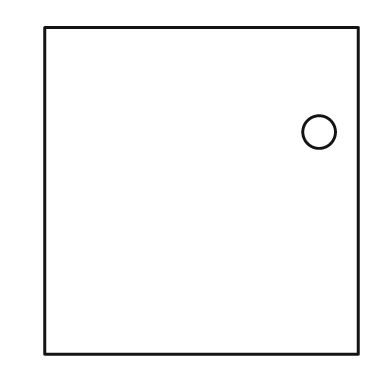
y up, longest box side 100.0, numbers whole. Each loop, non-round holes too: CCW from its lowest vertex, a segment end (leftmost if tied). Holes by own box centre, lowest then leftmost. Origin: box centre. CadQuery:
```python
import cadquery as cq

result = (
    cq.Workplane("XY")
    .moveTo(-48.0, -50.0)
    .lineTo(48.0, -50.0)
    .lineTo(48.0, 50.0)
    .lineTo(-48.0, 50.0)
    .close()
    .moveTo(36.0, 18.0)
    .circle(5.0)
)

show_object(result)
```